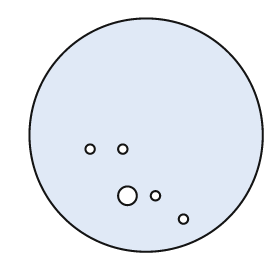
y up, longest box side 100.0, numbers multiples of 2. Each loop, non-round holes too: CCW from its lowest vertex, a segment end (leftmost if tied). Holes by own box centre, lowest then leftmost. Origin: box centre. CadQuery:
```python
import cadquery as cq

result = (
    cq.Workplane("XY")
    .moveTo(0.0, 0.0)
    .circle(50.0)
    .moveTo(16.0, -36.0)
    .circle(2.0)
    .moveTo(-8.0, -26.0)
    .circle(4.0)
    .moveTo(4.0, -26.0)
    .circle(2.0)
    .moveTo(-24.0, -6.0)
    .circle(2.0)
    .moveTo(-10.0, -6.0)
    .circle(2.0)
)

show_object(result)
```